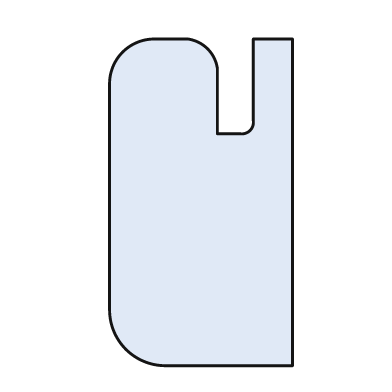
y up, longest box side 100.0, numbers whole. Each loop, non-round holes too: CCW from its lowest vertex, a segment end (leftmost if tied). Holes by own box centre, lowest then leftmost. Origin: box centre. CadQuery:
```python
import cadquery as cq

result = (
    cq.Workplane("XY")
    .moveTo(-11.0, -50.0)
    .lineTo(28.0, -50.0)
    .lineTo(28.0, 50.0)
    .lineTo(16.0, 50.0)
    .lineTo(16.0, 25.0)
    .threePointArc((15.0, 22.0), (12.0, 21.0))
    .lineTo(5.0, 21.0)
    .lineTo(5.0, 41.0)
    .threePointArc((2.0, 47.0), (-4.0, 50.0))
    .lineTo(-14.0, 50.0)
    .threePointArc((-24.0, 46.0), (-28.0, 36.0))
    .lineTo(-28.0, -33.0)
    .threePointArc((-23.0, -45.0), (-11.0, -50.0))
    .close()
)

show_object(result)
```